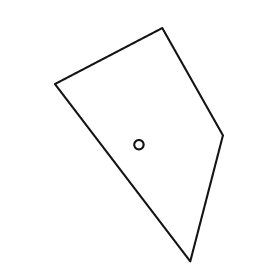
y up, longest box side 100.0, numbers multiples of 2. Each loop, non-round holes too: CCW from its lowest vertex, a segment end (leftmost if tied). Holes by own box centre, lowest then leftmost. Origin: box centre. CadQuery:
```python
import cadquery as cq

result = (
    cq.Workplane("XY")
    .moveTo(22.0, -50.0)
    .lineTo(36.0, 4.0)
    .lineTo(10.0, 50.0)
    .lineTo(-36.0, 26.0)
    .close()
    .moveTo(0.0, 0.0)
    .circle(2.0)
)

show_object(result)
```